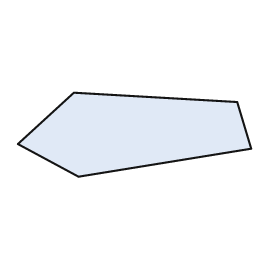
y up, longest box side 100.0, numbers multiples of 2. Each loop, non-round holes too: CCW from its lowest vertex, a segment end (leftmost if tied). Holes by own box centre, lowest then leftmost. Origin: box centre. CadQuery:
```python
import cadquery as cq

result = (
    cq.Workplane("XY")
    .moveTo(-24.0, -18.0)
    .lineTo(50.0, -6.0)
    .lineTo(44.0, 14.0)
    .lineTo(-26.0, 18.0)
    .lineTo(-50.0, -4.0)
    .close()
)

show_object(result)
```